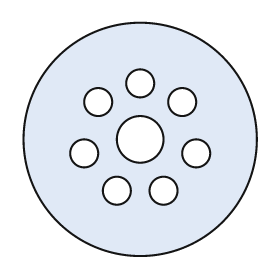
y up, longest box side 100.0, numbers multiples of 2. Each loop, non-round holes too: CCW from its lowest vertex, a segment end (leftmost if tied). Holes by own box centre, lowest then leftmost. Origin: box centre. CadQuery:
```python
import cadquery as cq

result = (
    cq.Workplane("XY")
    .moveTo(0.0, 0.0)
    .circle(50.0)
    .moveTo(-10.0, -22.0)
    .circle(6.0)
    .moveTo(10.0, -22.0)
    .circle(6.0)
    .moveTo(-24.0, -6.0)
    .circle(6.0)
    .moveTo(24.0, -6.0)
    .circle(6.0)
    .moveTo(0.0, 0.0)
    .circle(10.0)
    .moveTo(-18.0, 16.0)
    .circle(6.0)
    .moveTo(18.0, 16.0)
    .circle(6.0)
    .moveTo(0.0, 24.0)
    .circle(6.0)
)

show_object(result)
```